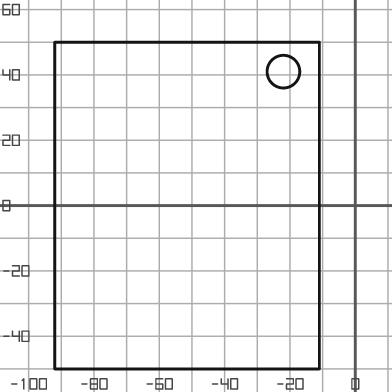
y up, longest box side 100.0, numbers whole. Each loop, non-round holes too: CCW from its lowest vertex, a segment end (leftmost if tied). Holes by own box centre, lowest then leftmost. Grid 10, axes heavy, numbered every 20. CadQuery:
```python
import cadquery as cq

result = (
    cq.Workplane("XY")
    .moveTo(-92.0, -50.0)
    .lineTo(-11.0, -50.0)
    .lineTo(-11.0, 50.0)
    .lineTo(-92.0, 50.0)
    .close()
    .moveTo(-22.0, 41.0)
    .circle(5.0)
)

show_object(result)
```